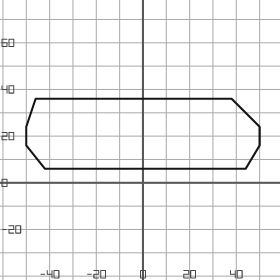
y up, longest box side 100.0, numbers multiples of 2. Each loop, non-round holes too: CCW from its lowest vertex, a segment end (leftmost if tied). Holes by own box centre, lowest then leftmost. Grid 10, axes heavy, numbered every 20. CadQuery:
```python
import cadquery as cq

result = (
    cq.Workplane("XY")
    .moveTo(-42.0, 6.0)
    .lineTo(44.0, 6.0)
    .lineTo(50.0, 16.0)
    .lineTo(50.0, 24.0)
    .lineTo(38.0, 36.0)
    .lineTo(-46.0, 36.0)
    .lineTo(-50.0, 24.0)
    .lineTo(-50.0, 16.0)
    .close()
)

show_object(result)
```